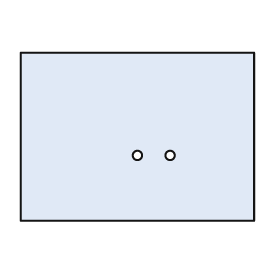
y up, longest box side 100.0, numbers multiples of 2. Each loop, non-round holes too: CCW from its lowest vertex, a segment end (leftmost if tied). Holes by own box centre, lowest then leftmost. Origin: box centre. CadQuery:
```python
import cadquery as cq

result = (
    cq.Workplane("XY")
    .moveTo(-50.0, -36.0)
    .lineTo(50.0, -36.0)
    .lineTo(50.0, 36.0)
    .lineTo(-50.0, 36.0)
    .close()
    .moveTo(0.0, -8.0)
    .circle(2.0)
    .moveTo(14.0, -8.0)
    .circle(2.0)
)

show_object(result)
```